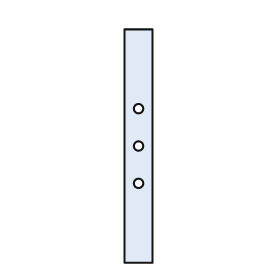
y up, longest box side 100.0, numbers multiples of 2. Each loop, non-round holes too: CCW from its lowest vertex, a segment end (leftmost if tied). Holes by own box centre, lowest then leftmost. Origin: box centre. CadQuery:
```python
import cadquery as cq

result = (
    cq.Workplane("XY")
    .moveTo(-6.0, -50.0)
    .lineTo(6.0, -50.0)
    .lineTo(6.0, 50.0)
    .lineTo(-6.0, 50.0)
    .close()
    .moveTo(0.0, -16.0)
    .circle(2.0)
    .moveTo(0.0, 0.0)
    .circle(2.0)
    .moveTo(0.0, 16.0)
    .circle(2.0)
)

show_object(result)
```